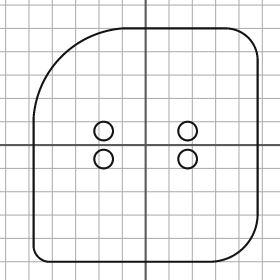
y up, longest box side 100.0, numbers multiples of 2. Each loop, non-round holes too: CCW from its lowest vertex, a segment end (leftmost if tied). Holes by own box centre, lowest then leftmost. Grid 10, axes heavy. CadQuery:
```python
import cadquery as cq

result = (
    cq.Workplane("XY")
    .moveTo(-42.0, -50.0)
    .lineTo(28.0, -50.0)
    .threePointArc((42.0, -44.0), (48.0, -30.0))
    .lineTo(48.0, 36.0)
    .threePointArc((44.0, 46.0), (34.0, 50.0))
    .lineTo(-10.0, 50.0)
    .threePointArc((-36.0, 38.0), (-48.0, 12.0))
    .lineTo(-48.0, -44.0)
    .threePointArc((-46.0, -48.0), (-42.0, -50.0))
    .close()
    .moveTo(-18.0, -6.0)
    .circle(4.0)
    .moveTo(18.0, -6.0)
    .circle(4.0)
    .moveTo(-18.0, 6.0)
    .circle(4.0)
    .moveTo(18.0, 6.0)
    .circle(4.0)
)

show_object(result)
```